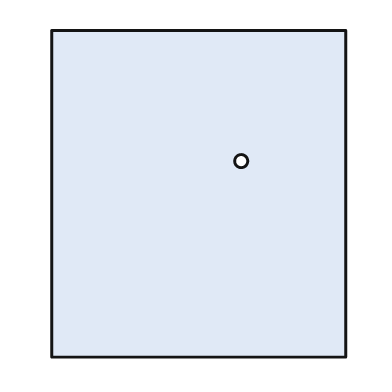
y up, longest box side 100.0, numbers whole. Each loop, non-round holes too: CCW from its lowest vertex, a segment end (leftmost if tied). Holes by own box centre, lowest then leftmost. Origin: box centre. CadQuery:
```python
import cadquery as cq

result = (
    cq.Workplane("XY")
    .moveTo(-45.0, -50.0)
    .lineTo(45.0, -50.0)
    .lineTo(45.0, 50.0)
    .lineTo(-45.0, 50.0)
    .close()
    .moveTo(13.0, 10.0)
    .circle(2.0)
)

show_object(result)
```